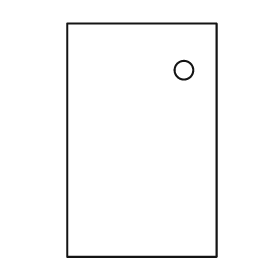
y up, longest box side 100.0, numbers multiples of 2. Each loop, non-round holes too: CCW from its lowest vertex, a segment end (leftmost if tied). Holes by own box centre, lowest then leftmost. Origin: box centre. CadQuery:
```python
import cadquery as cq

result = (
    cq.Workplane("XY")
    .moveTo(-32.0, -50.0)
    .lineTo(32.0, -50.0)
    .lineTo(32.0, 50.0)
    .lineTo(-32.0, 50.0)
    .close()
    .moveTo(18.0, 30.0)
    .circle(4.0)
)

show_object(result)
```